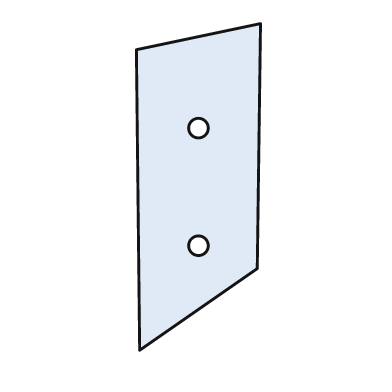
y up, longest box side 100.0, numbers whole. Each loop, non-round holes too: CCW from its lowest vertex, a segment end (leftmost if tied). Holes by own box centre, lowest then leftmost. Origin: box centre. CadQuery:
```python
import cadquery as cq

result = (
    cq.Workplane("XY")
    .moveTo(-18.0, -50.0)
    .lineTo(18.0, -25.0)
    .lineTo(19.0, 50.0)
    .lineTo(-19.0, 42.0)
    .close()
    .moveTo(0.0, -18.0)
    .circle(3.0)
    .moveTo(0.0, 18.0)
    .circle(3.0)
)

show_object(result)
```